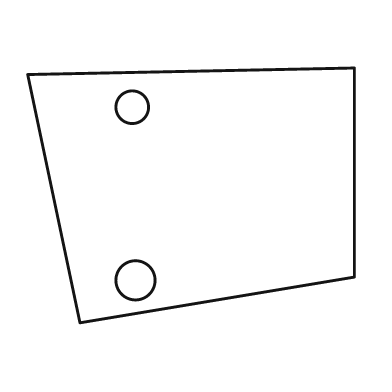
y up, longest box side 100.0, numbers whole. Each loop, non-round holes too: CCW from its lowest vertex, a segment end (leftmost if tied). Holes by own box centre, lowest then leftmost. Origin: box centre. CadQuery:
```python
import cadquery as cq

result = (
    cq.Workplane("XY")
    .moveTo(-34.0, -39.0)
    .lineTo(50.0, -25.0)
    .lineTo(50.0, 39.0)
    .lineTo(-50.0, 37.0)
    .close()
    .moveTo(-17.0, -26.0)
    .circle(6.0)
    .moveTo(-18.0, 27.0)
    .circle(5.0)
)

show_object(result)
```